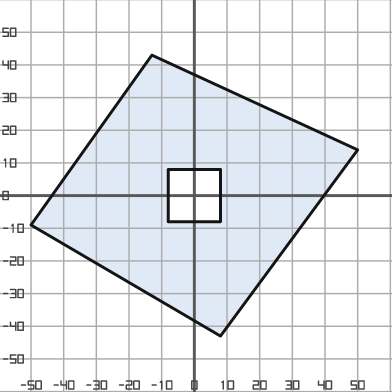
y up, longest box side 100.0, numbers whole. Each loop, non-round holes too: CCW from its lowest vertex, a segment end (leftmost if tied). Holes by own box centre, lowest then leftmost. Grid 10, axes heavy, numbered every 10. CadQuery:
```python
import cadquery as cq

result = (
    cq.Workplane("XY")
    .moveTo(8.0, -43.0)
    .lineTo(50.0, 14.0)
    .lineTo(-13.0, 43.0)
    .lineTo(-50.0, -9.0)
    .close()
    .moveTo(-8.0, -8.0)
    .lineTo(8.0, -8.0)
    .lineTo(8.0, 8.0)
    .lineTo(-8.0, 8.0)
    .close()
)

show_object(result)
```